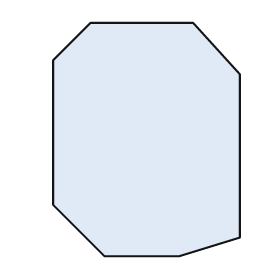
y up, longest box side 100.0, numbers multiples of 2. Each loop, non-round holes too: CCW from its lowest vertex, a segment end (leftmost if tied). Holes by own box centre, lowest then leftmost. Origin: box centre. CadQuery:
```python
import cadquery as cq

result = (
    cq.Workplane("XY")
    .moveTo(-18.0, -50.0)
    .lineTo(14.0, -50.0)
    .lineTo(40.0, -42.0)
    .lineTo(40.0, 28.0)
    .lineTo(20.0, 50.0)
    .lineTo(-24.0, 50.0)
    .lineTo(-40.0, 34.0)
    .lineTo(-40.0, -28.0)
    .close()
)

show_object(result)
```